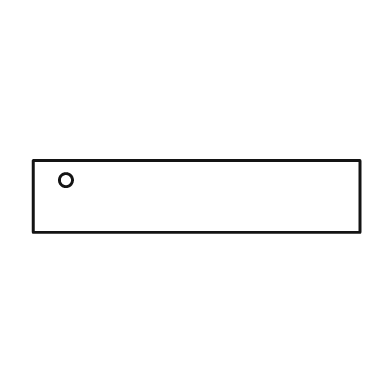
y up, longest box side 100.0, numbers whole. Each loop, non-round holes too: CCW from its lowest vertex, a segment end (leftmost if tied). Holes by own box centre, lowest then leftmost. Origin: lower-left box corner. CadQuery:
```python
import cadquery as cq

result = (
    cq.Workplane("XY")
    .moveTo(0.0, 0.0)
    .lineTo(100.0, 0.0)
    .lineTo(100.0, 22.0)
    .lineTo(0.0, 22.0)
    .close()
    .moveTo(10.0, 16.0)
    .circle(2.0)
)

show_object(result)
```